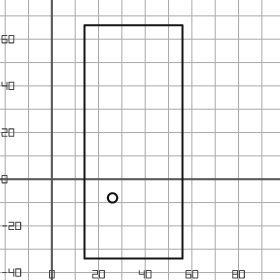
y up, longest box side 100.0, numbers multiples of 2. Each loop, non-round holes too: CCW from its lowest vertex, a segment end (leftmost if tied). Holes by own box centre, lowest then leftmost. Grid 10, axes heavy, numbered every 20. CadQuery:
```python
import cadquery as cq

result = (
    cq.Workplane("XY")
    .moveTo(14.0, -34.0)
    .lineTo(56.0, -34.0)
    .lineTo(56.0, 66.0)
    .lineTo(14.0, 66.0)
    .close()
    .moveTo(26.0, -8.0)
    .circle(2.0)
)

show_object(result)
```